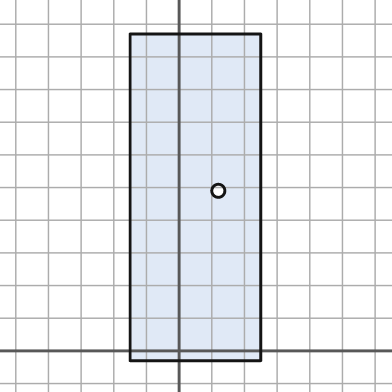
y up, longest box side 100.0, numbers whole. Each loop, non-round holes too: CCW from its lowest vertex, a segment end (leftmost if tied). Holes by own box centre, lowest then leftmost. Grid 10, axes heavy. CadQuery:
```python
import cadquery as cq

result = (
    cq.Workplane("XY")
    .moveTo(-15.0, -3.0)
    .lineTo(25.0, -3.0)
    .lineTo(25.0, 97.0)
    .lineTo(-15.0, 97.0)
    .close()
    .moveTo(12.0, 49.0)
    .circle(2.0)
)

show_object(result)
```